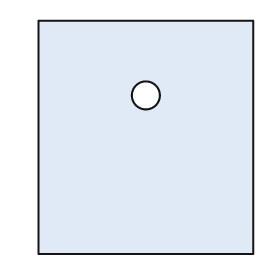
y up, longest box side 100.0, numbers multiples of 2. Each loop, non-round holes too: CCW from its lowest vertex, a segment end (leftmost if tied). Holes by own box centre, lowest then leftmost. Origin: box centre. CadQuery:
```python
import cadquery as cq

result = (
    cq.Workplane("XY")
    .moveTo(-46.0, -50.0)
    .lineTo(46.0, -50.0)
    .lineTo(46.0, 50.0)
    .lineTo(-46.0, 50.0)
    .close()
    .moveTo(0.0, 18.0)
    .circle(6.0)
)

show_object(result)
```